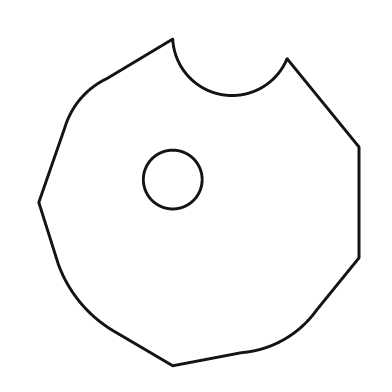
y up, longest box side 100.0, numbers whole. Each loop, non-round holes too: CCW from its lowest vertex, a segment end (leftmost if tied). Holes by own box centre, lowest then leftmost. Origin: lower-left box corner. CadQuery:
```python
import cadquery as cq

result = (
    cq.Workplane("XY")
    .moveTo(41.0, 0.0)
    .lineTo(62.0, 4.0)
    .threePointArc((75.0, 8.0), (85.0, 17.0))
    .lineTo(98.0, 33.0)
    .lineTo(98.0, 67.0)
    .lineTo(76.0, 94.0)
    .threePointArc((56.0, 83.0), (41.0, 100.0))
    .lineTo(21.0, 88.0)
    .threePointArc((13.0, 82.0), (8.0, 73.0))
    .lineTo(0.0, 50.0)
    .lineTo(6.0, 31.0)
    .threePointArc((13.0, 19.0), (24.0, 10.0))
    .close()
    .moveTo(41.0, 57.0)
    .circle(9.0)
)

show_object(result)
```